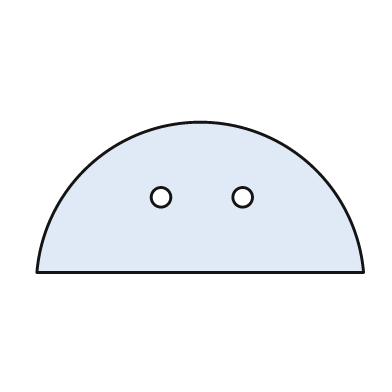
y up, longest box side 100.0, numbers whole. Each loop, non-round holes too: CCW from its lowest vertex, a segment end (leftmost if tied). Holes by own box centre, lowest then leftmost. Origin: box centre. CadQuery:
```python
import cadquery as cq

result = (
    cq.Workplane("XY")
    .moveTo(-50.0, -23.0)
    .lineTo(50.0, -23.0)
    .threePointArc((0.0, 23.0), (-50.0, -23.0))
    .close()
    .moveTo(-12.0, 0.0)
    .circle(3.0)
    .moveTo(13.0, 0.0)
    .circle(3.0)
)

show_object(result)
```